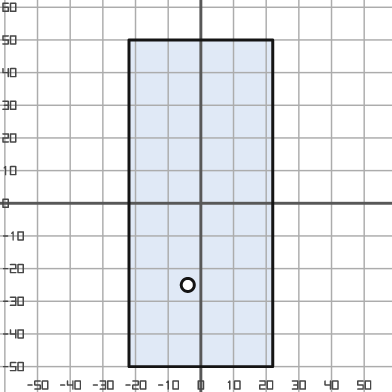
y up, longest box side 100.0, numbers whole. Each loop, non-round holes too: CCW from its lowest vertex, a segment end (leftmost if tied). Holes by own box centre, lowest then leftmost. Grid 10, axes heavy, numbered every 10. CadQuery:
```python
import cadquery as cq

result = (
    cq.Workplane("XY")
    .moveTo(-22.0, -50.0)
    .lineTo(22.0, -50.0)
    .lineTo(22.0, 50.0)
    .lineTo(-22.0, 50.0)
    .close()
    .moveTo(-4.0, -25.0)
    .circle(2.0)
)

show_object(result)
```